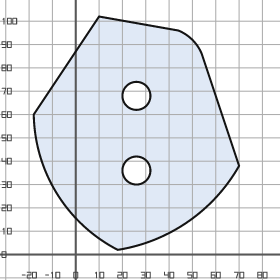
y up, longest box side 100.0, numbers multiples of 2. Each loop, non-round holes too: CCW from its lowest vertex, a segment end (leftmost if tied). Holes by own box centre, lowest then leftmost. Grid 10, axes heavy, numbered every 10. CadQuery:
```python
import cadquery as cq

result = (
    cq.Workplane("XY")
    .moveTo(18.0, 2.0)
    .threePointArc((48.0, 14.0), (70.0, 38.0))
    .lineTo(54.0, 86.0)
    .threePointArc((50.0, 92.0), (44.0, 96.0))
    .lineTo(10.0, 102.0)
    .lineTo(-18.0, 60.0)
    .threePointArc((-8.0, 26.0), (18.0, 2.0))
    .close()
    .moveTo(26.0, 36.0)
    .circle(6.0)
    .moveTo(26.0, 68.0)
    .circle(6.0)
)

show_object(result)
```